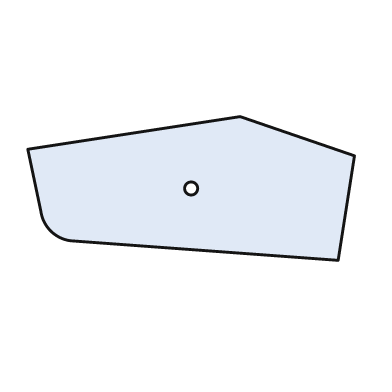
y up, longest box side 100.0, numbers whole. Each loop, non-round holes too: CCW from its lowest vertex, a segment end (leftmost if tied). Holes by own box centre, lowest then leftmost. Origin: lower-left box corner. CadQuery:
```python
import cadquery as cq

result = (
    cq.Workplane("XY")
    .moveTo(95.0, 0.0)
    .lineTo(100.0, 32.0)
    .lineTo(65.0, 44.0)
    .lineTo(0.0, 34.0)
    .lineTo(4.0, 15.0)
    .threePointArc((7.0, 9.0), (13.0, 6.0))
    .close()
    .moveTo(50.0, 22.0)
    .circle(2.0)
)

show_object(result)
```